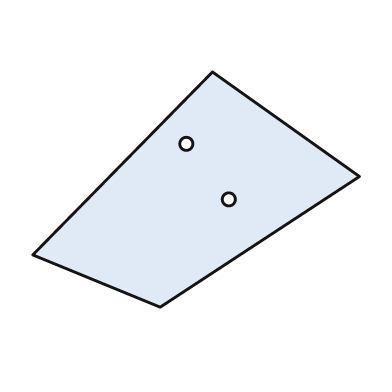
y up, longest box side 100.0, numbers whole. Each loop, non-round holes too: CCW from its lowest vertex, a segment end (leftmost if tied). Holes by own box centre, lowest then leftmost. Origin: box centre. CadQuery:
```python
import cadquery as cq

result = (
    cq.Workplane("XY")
    .moveTo(-11.0, -36.0)
    .lineTo(50.0, 4.0)
    .lineTo(5.0, 36.0)
    .lineTo(-50.0, -20.0)
    .close()
    .moveTo(10.0, -3.0)
    .circle(2.0)
    .moveTo(-3.0, 14.0)
    .circle(2.0)
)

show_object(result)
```